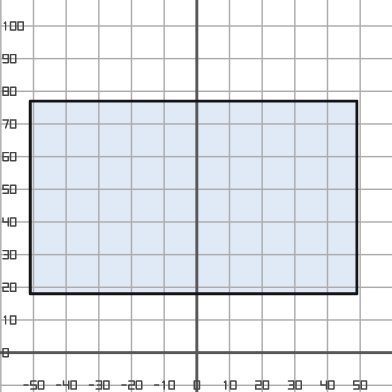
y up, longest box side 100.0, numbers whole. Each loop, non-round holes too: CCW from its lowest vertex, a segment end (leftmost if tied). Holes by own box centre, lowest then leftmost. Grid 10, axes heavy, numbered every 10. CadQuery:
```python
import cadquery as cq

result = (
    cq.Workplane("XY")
    .moveTo(-51.0, 18.0)
    .lineTo(49.0, 18.0)
    .lineTo(49.0, 77.0)
    .lineTo(-51.0, 77.0)
    .close()
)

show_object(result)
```